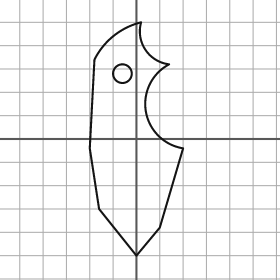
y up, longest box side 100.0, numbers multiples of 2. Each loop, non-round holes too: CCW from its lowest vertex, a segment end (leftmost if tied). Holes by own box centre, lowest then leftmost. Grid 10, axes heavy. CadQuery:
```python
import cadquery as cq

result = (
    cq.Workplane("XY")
    .moveTo(0.0, -50.0)
    .lineTo(10.0, -38.0)
    .lineTo(20.0, -4.0)
    .threePointArc((4.0, 12.0), (14.0, 32.0))
    .threePointArc((4.0, 38.0), (2.0, 50.0))
    .threePointArc((-10.0, 44.0), (-18.0, 34.0))
    .lineTo(-20.0, -4.0)
    .lineTo(-16.0, -30.0)
    .close()
    .moveTo(-6.0, 28.0)
    .circle(4.0)
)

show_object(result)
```